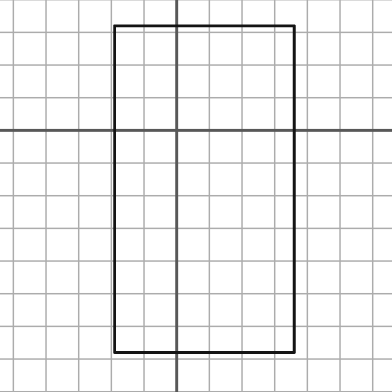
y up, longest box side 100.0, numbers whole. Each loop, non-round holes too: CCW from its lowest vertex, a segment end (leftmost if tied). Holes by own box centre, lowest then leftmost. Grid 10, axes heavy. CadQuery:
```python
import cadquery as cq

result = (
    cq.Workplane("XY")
    .moveTo(-19.0, -68.0)
    .lineTo(36.0, -68.0)
    .lineTo(36.0, 32.0)
    .lineTo(-19.0, 32.0)
    .close()
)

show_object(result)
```